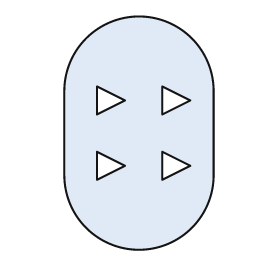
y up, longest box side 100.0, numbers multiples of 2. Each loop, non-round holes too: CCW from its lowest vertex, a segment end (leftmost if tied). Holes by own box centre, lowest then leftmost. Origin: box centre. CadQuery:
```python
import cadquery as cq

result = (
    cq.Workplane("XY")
    .moveTo(-32.0, -18.0)
    .threePointArc((0.0, -50.0), (32.0, -18.0))
    .lineTo(32.0, 18.0)
    .threePointArc((0.0, 50.0), (-32.0, 18.0))
    .close()
    .moveTo(-18.0, -20.0)
    .lineTo(-6.0, -14.0)
    .lineTo(-18.0, -8.0)
    .close()
    .moveTo(10.0, -20.0)
    .lineTo(22.0, -14.0)
    .lineTo(10.0, -8.0)
    .close()
    .moveTo(-18.0, 8.0)
    .lineTo(-6.0, 14.0)
    .lineTo(-18.0, 20.0)
    .close()
    .moveTo(10.0, 8.0)
    .lineTo(22.0, 14.0)
    .lineTo(10.0, 20.0)
    .close()
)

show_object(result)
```